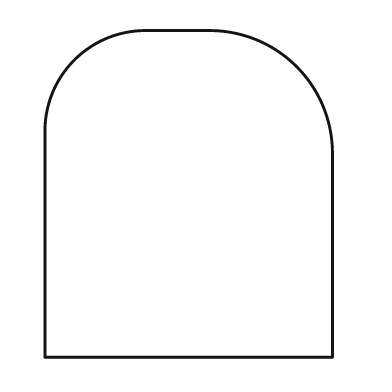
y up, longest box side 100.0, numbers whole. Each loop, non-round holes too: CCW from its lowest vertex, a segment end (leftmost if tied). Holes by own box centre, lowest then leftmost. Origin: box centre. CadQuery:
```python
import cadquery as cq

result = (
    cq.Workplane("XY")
    .moveTo(-44.0, -50.0)
    .lineTo(44.0, -50.0)
    .lineTo(44.0, 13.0)
    .threePointArc((33.0, 39.0), (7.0, 50.0))
    .lineTo(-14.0, 50.0)
    .threePointArc((-35.0, 41.0), (-44.0, 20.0))
    .close()
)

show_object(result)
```